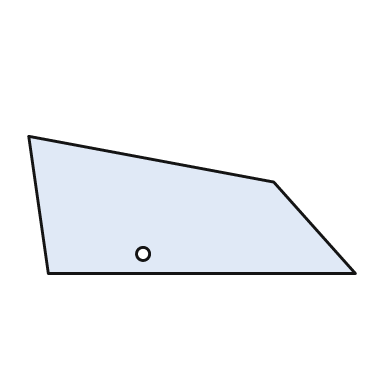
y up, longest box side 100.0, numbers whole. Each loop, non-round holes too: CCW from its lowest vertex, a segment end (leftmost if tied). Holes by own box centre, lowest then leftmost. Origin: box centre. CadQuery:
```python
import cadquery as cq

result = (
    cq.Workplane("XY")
    .moveTo(-44.0, -21.0)
    .lineTo(50.0, -21.0)
    .lineTo(25.0, 7.0)
    .lineTo(-50.0, 21.0)
    .close()
    .moveTo(-15.0, -15.0)
    .circle(2.0)
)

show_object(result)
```